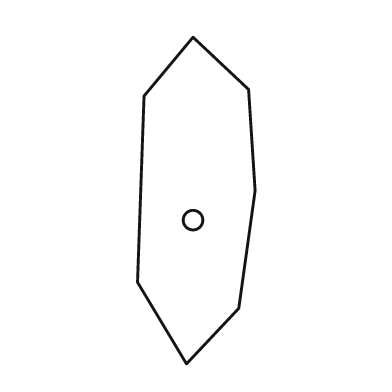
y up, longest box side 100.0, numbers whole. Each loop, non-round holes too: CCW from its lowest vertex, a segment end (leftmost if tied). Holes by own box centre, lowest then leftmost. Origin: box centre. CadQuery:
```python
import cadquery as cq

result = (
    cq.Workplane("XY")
    .moveTo(-3.0, -50.0)
    .lineTo(13.0, -33.0)
    .lineTo(18.0, 3.0)
    .lineTo(16.0, 34.0)
    .lineTo(-1.0, 50.0)
    .lineTo(-16.0, 32.0)
    .lineTo(-18.0, -25.0)
    .close()
    .moveTo(-1.0, -6.0)
    .circle(3.0)
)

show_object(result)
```